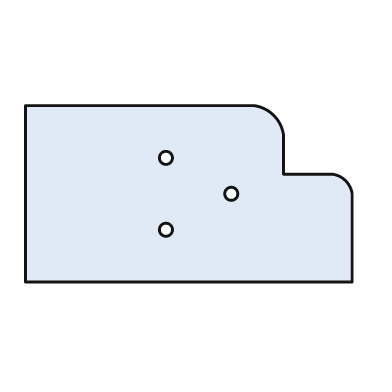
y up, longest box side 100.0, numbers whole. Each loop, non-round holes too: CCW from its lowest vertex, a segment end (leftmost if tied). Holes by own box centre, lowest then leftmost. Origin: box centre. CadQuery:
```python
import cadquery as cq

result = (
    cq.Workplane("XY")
    .moveTo(-50.0, -27.0)
    .lineTo(50.0, -27.0)
    .lineTo(50.0, 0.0)
    .threePointArc((48.0, 4.0), (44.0, 6.0))
    .lineTo(29.0, 6.0)
    .lineTo(29.0, 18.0)
    .threePointArc((26.0, 24.0), (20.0, 27.0))
    .lineTo(-50.0, 27.0)
    .close()
    .moveTo(-7.0, -11.0)
    .circle(2.0)
    .moveTo(13.0, 0.0)
    .circle(2.0)
    .moveTo(-7.0, 11.0)
    .circle(2.0)
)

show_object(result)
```